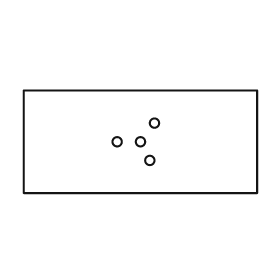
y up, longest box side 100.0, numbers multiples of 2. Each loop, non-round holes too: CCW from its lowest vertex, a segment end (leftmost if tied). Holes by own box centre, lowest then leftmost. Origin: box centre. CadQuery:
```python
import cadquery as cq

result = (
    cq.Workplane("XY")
    .moveTo(-50.0, -22.0)
    .lineTo(50.0, -22.0)
    .lineTo(50.0, 22.0)
    .lineTo(-50.0, 22.0)
    .close()
    .moveTo(4.0, -8.0)
    .circle(2.0)
    .moveTo(-10.0, 0.0)
    .circle(2.0)
    .moveTo(0.0, 0.0)
    .circle(2.0)
    .moveTo(6.0, 8.0)
    .circle(2.0)
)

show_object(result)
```